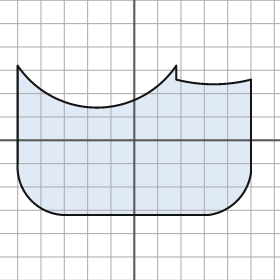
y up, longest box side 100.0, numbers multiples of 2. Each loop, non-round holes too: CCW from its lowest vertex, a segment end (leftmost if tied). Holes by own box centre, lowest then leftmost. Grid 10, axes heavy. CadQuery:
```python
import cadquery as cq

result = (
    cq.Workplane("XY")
    .moveTo(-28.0, -32.0)
    .lineTo(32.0, -32.0)
    .threePointArc((44.0, -26.0), (50.0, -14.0))
    .lineTo(50.0, 26.0)
    .threePointArc((34.0, 24.0), (18.0, 26.0))
    .lineTo(18.0, 32.0)
    .threePointArc((-16.0, 14.0), (-50.0, 32.0))
    .lineTo(-50.0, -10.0)
    .threePointArc((-44.0, -26.0), (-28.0, -32.0))
    .close()
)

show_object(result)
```